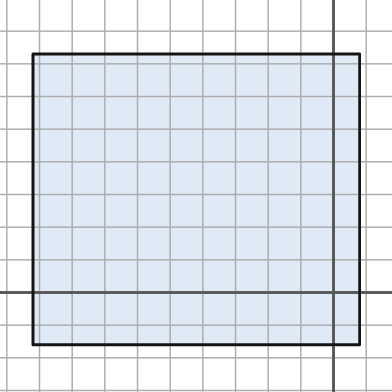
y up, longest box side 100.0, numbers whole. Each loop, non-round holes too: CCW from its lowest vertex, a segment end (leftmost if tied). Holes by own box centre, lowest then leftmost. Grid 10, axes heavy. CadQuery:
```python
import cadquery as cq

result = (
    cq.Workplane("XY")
    .moveTo(-92.0, -16.0)
    .lineTo(8.0, -16.0)
    .lineTo(8.0, 73.0)
    .lineTo(-92.0, 73.0)
    .close()
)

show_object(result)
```